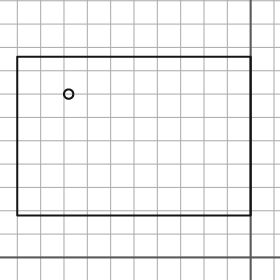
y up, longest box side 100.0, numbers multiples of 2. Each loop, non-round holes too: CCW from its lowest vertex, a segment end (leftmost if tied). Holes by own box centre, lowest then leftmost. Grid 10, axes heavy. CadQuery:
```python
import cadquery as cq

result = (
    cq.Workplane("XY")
    .moveTo(-100.0, 18.0)
    .lineTo(0.0, 18.0)
    .lineTo(0.0, 86.0)
    .lineTo(-100.0, 86.0)
    .close()
    .moveTo(-78.0, 70.0)
    .circle(2.0)
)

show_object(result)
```